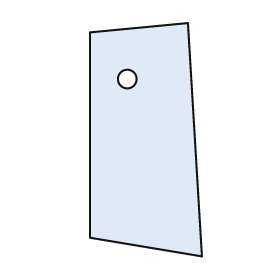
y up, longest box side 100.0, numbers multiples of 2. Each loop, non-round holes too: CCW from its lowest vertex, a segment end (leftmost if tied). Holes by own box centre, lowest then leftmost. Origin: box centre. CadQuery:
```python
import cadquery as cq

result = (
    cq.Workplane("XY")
    .moveTo(24.0, -50.0)
    .lineTo(18.0, 50.0)
    .lineTo(-24.0, 46.0)
    .lineTo(-24.0, -42.0)
    .close()
    .moveTo(-8.0, 26.0)
    .circle(4.0)
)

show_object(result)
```